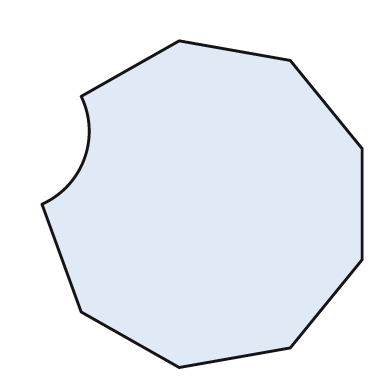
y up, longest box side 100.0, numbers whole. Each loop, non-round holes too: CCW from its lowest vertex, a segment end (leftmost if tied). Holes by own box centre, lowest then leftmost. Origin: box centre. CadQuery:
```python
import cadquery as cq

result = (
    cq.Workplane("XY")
    .moveTo(-7.0, -50.0)
    .lineTo(27.0, -44.0)
    .lineTo(49.0, -17.0)
    .lineTo(49.0, 17.0)
    .lineTo(27.0, 44.0)
    .lineTo(-7.0, 50.0)
    .lineTo(-37.0, 33.0)
    .threePointArc((-36.0, 14.0), (-49.0, 0.0))
    .lineTo(-37.0, -33.0)
    .close()
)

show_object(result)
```